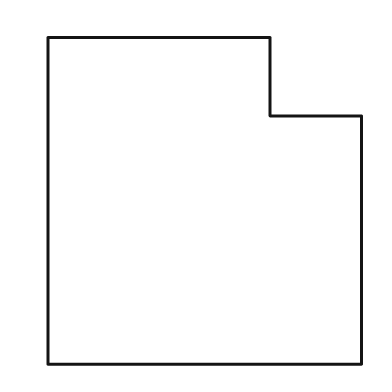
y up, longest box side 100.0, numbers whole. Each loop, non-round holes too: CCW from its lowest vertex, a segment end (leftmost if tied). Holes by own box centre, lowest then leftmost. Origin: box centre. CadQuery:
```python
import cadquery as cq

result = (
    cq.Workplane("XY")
    .moveTo(-48.0, -50.0)
    .lineTo(48.0, -50.0)
    .lineTo(48.0, 26.0)
    .lineTo(20.0, 26.0)
    .lineTo(20.0, 50.0)
    .lineTo(-48.0, 50.0)
    .close()
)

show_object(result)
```